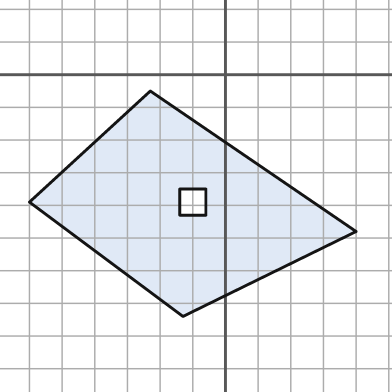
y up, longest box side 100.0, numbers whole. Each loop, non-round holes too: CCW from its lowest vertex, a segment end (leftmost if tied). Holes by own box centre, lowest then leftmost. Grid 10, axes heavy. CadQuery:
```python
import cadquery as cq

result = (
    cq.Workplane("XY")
    .moveTo(-13.0, -74.0)
    .lineTo(40.0, -48.0)
    .lineTo(-23.0, -5.0)
    .lineTo(-60.0, -39.0)
    .close()
    .moveTo(-14.0, -43.0)
    .lineTo(-6.0, -43.0)
    .lineTo(-6.0, -35.0)
    .lineTo(-14.0, -35.0)
    .close()
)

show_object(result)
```